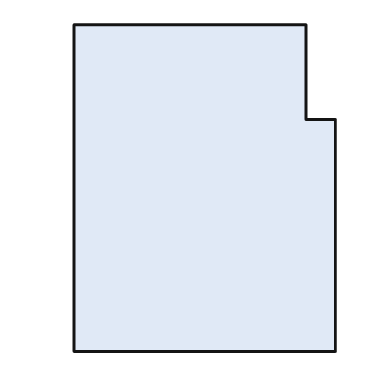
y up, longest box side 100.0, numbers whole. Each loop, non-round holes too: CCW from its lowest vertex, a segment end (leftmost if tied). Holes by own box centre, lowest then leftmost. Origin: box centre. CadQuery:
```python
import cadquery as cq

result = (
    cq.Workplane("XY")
    .moveTo(-40.0, -50.0)
    .lineTo(40.0, -50.0)
    .lineTo(40.0, 21.0)
    .lineTo(31.0, 21.0)
    .lineTo(31.0, 50.0)
    .lineTo(-40.0, 50.0)
    .close()
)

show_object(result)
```